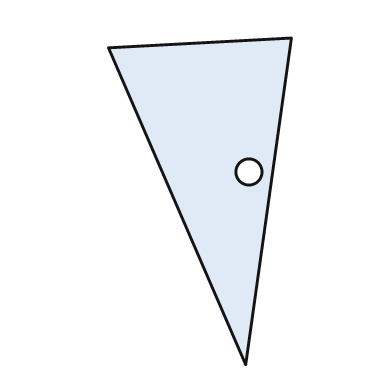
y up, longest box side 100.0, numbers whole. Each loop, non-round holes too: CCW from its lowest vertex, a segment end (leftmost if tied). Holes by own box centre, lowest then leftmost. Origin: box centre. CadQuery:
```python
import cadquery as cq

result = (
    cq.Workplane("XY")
    .moveTo(14.0, -50.0)
    .lineTo(28.0, 50.0)
    .lineTo(-28.0, 47.0)
    .close()
    .moveTo(15.0, 9.0)
    .circle(4.0)
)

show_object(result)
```